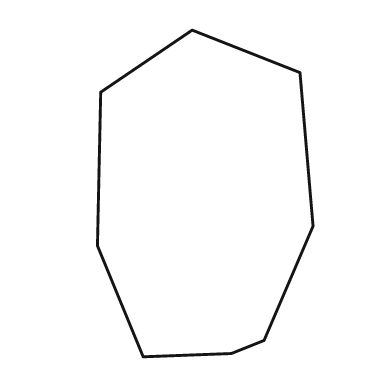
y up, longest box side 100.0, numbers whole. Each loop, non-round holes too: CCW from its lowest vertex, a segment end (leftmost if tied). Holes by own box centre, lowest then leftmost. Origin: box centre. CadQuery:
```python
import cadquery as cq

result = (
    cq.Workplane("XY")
    .moveTo(-19.0, -50.0)
    .lineTo(8.0, -49.0)
    .lineTo(18.0, -45.0)
    .lineTo(33.0, -10.0)
    .lineTo(29.0, 37.0)
    .lineTo(-4.0, 50.0)
    .lineTo(-32.0, 31.0)
    .lineTo(-33.0, -16.0)
    .close()
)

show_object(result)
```